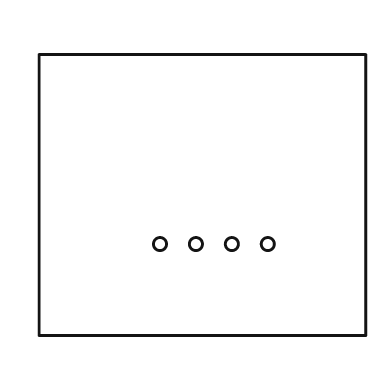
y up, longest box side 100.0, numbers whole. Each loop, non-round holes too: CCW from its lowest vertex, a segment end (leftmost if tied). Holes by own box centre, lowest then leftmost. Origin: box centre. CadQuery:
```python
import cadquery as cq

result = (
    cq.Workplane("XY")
    .moveTo(-50.0, -43.0)
    .lineTo(50.0, -43.0)
    .lineTo(50.0, 43.0)
    .lineTo(-50.0, 43.0)
    .close()
    .moveTo(-13.0, -15.0)
    .circle(2.0)
    .moveTo(-2.0, -15.0)
    .circle(2.0)
    .moveTo(9.0, -15.0)
    .circle(2.0)
    .moveTo(20.0, -15.0)
    .circle(2.0)
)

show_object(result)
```